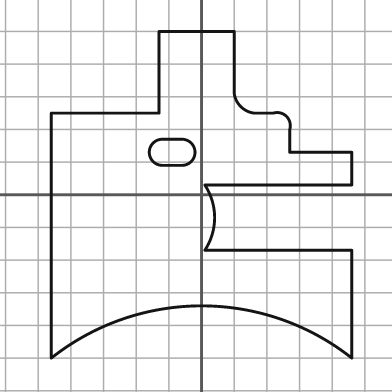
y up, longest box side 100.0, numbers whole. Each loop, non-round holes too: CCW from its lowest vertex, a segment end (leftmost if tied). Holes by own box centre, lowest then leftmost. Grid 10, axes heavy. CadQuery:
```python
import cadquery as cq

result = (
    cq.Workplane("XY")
    .moveTo(-46.0, -50.0)
    .threePointArc((0.0, -34.0), (46.0, -50.0))
    .lineTo(46.0, -17.0)
    .lineTo(1.0, -17.0)
    .threePointArc((4.0, -7.0), (1.0, 3.0))
    .lineTo(46.0, 3.0)
    .lineTo(46.0, 13.0)
    .lineTo(27.0, 13.0)
    .lineTo(27.0, 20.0)
    .threePointArc((26.0, 24.0), (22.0, 25.0))
    .lineTo(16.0, 25.0)
    .threePointArc((12.0, 27.0), (10.0, 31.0))
    .lineTo(10.0, 50.0)
    .lineTo(-13.0, 50.0)
    .lineTo(-13.0, 25.0)
    .lineTo(-46.0, 25.0)
    .close()
    .moveTo(-12.0, 9.0)
    .lineTo(-6.0, 9.0)
    .threePointArc((-2.0, 13.0), (-6.0, 17.0))
    .lineTo(-12.0, 17.0)
    .threePointArc((-16.0, 13.0), (-12.0, 9.0))
    .close()
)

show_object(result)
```